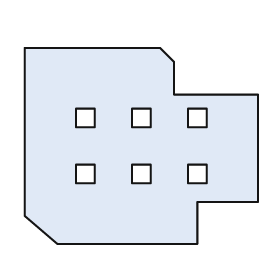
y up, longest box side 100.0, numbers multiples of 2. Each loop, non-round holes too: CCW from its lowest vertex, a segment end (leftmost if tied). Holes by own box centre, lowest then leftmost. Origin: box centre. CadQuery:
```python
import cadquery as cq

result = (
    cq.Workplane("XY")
    .moveTo(-36.0, -42.0)
    .lineTo(24.0, -42.0)
    .lineTo(24.0, -24.0)
    .lineTo(50.0, -24.0)
    .lineTo(50.0, 22.0)
    .lineTo(14.0, 22.0)
    .lineTo(14.0, 36.0)
    .lineTo(8.0, 42.0)
    .lineTo(-50.0, 42.0)
    .lineTo(-50.0, -30.0)
    .close()
    .moveTo(-28.0, -16.0)
    .lineTo(-20.0, -16.0)
    .lineTo(-20.0, -8.0)
    .lineTo(-28.0, -8.0)
    .close()
    .moveTo(-4.0, -16.0)
    .lineTo(4.0, -16.0)
    .lineTo(4.0, -8.0)
    .lineTo(-4.0, -8.0)
    .close()
    .moveTo(20.0, -16.0)
    .lineTo(28.0, -16.0)
    .lineTo(28.0, -8.0)
    .lineTo(20.0, -8.0)
    .close()
    .moveTo(-28.0, 8.0)
    .lineTo(-20.0, 8.0)
    .lineTo(-20.0, 16.0)
    .lineTo(-28.0, 16.0)
    .close()
    .moveTo(-4.0, 8.0)
    .lineTo(4.0, 8.0)
    .lineTo(4.0, 16.0)
    .lineTo(-4.0, 16.0)
    .close()
    .moveTo(20.0, 8.0)
    .lineTo(28.0, 8.0)
    .lineTo(28.0, 16.0)
    .lineTo(20.0, 16.0)
    .close()
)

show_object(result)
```